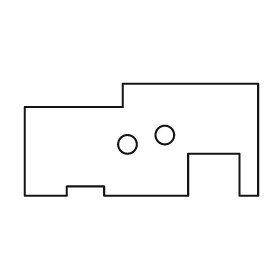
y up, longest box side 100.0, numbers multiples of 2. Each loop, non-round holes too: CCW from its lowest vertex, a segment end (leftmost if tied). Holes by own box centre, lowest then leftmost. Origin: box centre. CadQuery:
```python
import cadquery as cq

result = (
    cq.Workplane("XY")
    .moveTo(-50.0, -24.0)
    .lineTo(-32.0, -24.0)
    .lineTo(-32.0, -20.0)
    .lineTo(-16.0, -20.0)
    .lineTo(-16.0, -24.0)
    .lineTo(20.0, -24.0)
    .lineTo(20.0, -6.0)
    .lineTo(42.0, -6.0)
    .lineTo(42.0, -24.0)
    .lineTo(50.0, -24.0)
    .lineTo(50.0, 24.0)
    .lineTo(-8.0, 24.0)
    .lineTo(-8.0, 14.0)
    .lineTo(-50.0, 14.0)
    .close()
    .moveTo(-6.0, -2.0)
    .circle(4.0)
    .moveTo(10.0, 2.0)
    .circle(4.0)
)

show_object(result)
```